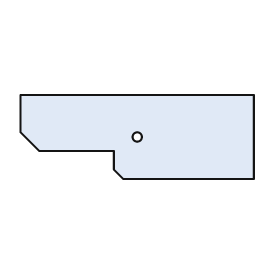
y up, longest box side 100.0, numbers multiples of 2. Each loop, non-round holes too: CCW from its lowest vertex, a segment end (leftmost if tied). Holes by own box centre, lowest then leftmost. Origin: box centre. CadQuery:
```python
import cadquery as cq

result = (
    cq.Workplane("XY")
    .moveTo(-6.0, -18.0)
    .lineTo(50.0, -18.0)
    .lineTo(50.0, 18.0)
    .lineTo(-50.0, 18.0)
    .lineTo(-50.0, 2.0)
    .lineTo(-42.0, -6.0)
    .lineTo(-10.0, -6.0)
    .lineTo(-10.0, -14.0)
    .close()
    .moveTo(0.0, 0.0)
    .circle(2.0)
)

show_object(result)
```